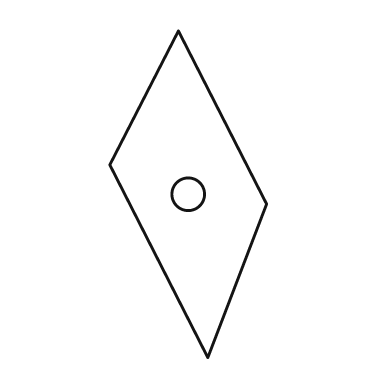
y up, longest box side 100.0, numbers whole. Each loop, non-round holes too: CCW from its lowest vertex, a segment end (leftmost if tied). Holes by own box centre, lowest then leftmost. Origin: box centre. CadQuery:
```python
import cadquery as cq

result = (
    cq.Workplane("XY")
    .moveTo(6.0, -50.0)
    .lineTo(24.0, -3.0)
    .lineTo(-3.0, 50.0)
    .lineTo(-24.0, 9.0)
    .close()
    .moveTo(0.0, 0.0)
    .circle(5.0)
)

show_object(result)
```